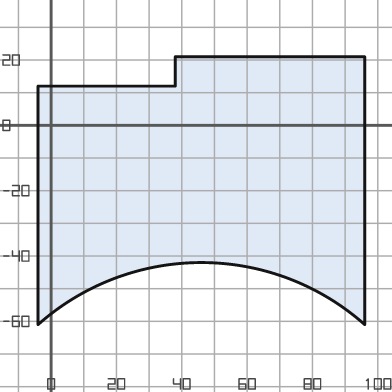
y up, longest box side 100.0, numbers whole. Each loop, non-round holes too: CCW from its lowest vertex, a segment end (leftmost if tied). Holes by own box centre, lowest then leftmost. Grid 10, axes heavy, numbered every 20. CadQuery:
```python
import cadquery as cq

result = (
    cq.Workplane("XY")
    .moveTo(-4.0, -61.0)
    .threePointArc((46.0, -42.0), (96.0, -61.0))
    .lineTo(96.0, 21.0)
    .lineTo(38.0, 21.0)
    .lineTo(38.0, 12.0)
    .lineTo(-4.0, 12.0)
    .close()
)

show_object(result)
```